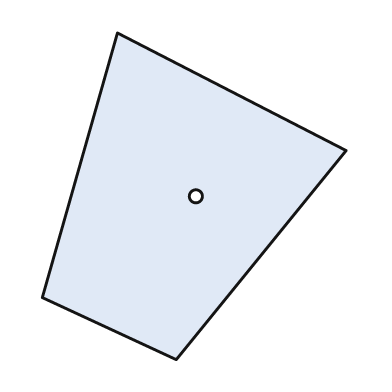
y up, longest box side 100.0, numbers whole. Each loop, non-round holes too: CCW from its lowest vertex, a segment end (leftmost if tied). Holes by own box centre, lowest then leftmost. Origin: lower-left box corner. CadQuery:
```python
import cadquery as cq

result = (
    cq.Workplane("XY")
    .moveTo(41.0, 0.0)
    .lineTo(93.0, 64.0)
    .lineTo(23.0, 100.0)
    .lineTo(0.0, 19.0)
    .close()
    .moveTo(47.0, 50.0)
    .circle(2.0)
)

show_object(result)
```